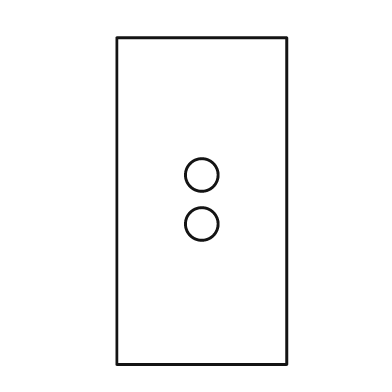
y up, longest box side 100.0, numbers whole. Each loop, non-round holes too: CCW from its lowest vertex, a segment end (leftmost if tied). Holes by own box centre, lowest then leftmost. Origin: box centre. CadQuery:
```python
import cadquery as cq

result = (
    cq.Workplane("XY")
    .moveTo(-26.0, -50.0)
    .lineTo(26.0, -50.0)
    .lineTo(26.0, 50.0)
    .lineTo(-26.0, 50.0)
    .close()
    .moveTo(0.0, -7.0)
    .circle(5.0)
    .moveTo(0.0, 8.0)
    .circle(5.0)
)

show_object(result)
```